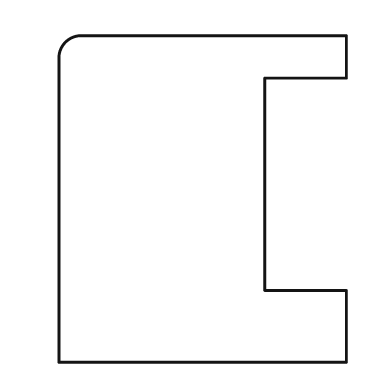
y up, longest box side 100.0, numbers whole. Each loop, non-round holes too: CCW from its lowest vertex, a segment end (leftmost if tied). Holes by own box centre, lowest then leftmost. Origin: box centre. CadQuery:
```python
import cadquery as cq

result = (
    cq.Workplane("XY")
    .moveTo(-44.0, -50.0)
    .lineTo(44.0, -50.0)
    .lineTo(44.0, -28.0)
    .lineTo(19.0, -28.0)
    .lineTo(19.0, 37.0)
    .lineTo(44.0, 37.0)
    .lineTo(44.0, 50.0)
    .lineTo(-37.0, 50.0)
    .threePointArc((-42.0, 48.0), (-44.0, 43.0))
    .close()
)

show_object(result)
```